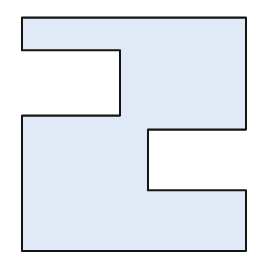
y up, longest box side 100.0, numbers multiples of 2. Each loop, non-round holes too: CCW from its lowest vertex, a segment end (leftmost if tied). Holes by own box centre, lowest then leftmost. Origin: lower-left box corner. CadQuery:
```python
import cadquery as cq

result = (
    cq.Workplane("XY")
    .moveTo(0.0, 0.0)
    .lineTo(96.0, 0.0)
    .lineTo(96.0, 26.0)
    .lineTo(54.0, 26.0)
    .lineTo(54.0, 52.0)
    .lineTo(96.0, 52.0)
    .lineTo(96.0, 100.0)
    .lineTo(0.0, 100.0)
    .lineTo(0.0, 86.0)
    .lineTo(42.0, 86.0)
    .lineTo(42.0, 58.0)
    .lineTo(0.0, 58.0)
    .close()
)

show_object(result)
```